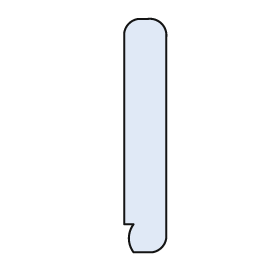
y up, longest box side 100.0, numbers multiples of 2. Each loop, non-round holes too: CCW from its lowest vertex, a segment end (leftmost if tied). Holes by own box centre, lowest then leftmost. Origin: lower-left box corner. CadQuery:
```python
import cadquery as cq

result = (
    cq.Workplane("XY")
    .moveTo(4.0, 0.0)
    .lineTo(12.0, 0.0)
    .threePointArc((16.0, 2.0), (18.0, 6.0))
    .lineTo(18.0, 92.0)
    .threePointArc((16.0, 98.0), (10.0, 100.0))
    .lineTo(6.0, 100.0)
    .threePointArc((2.0, 98.0), (0.0, 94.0))
    .lineTo(0.0, 12.0)
    .lineTo(4.0, 12.0)
    .threePointArc((2.0, 6.0), (4.0, 0.0))
    .close()
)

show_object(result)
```